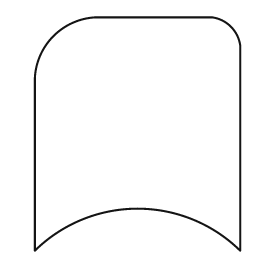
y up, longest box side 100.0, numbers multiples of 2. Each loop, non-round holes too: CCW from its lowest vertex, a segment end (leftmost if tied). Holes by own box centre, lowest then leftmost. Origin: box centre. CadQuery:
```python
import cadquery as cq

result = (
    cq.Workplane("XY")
    .moveTo(-44.0, -50.0)
    .threePointArc((0.0, -32.0), (44.0, -50.0))
    .lineTo(44.0, 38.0)
    .threePointArc((40.0, 46.0), (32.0, 50.0))
    .lineTo(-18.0, 50.0)
    .threePointArc((-36.0, 42.0), (-44.0, 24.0))
    .close()
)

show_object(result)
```